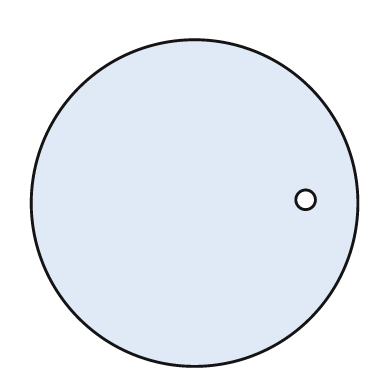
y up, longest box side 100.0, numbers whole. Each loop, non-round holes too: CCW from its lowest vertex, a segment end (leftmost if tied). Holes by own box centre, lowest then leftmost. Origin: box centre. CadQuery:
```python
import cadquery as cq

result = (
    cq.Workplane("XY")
    .moveTo(0.0, 0.0)
    .circle(50.0)
    .moveTo(34.0, 1.0)
    .circle(3.0)
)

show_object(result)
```